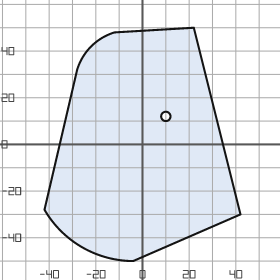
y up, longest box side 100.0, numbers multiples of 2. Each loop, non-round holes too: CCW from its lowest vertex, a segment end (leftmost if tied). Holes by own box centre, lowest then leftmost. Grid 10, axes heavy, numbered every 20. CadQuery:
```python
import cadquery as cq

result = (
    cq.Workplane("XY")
    .moveTo(-4.0, -50.0)
    .lineTo(42.0, -30.0)
    .lineTo(22.0, 50.0)
    .lineTo(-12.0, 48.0)
    .threePointArc((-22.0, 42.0), (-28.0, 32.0))
    .lineTo(-42.0, -28.0)
    .threePointArc((-26.0, -44.0), (-4.0, -50.0))
    .close()
    .moveTo(10.0, 12.0)
    .circle(2.0)
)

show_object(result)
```